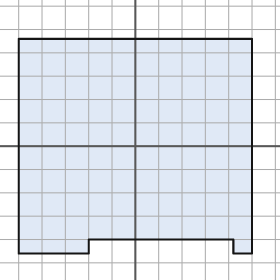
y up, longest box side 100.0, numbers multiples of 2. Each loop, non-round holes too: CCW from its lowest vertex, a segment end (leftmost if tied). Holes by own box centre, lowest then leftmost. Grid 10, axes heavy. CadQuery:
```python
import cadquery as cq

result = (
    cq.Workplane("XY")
    .moveTo(-50.0, -46.0)
    .lineTo(-20.0, -46.0)
    .lineTo(-20.0, -40.0)
    .lineTo(42.0, -40.0)
    .lineTo(42.0, -46.0)
    .lineTo(50.0, -46.0)
    .lineTo(50.0, 46.0)
    .lineTo(-50.0, 46.0)
    .close()
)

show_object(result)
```